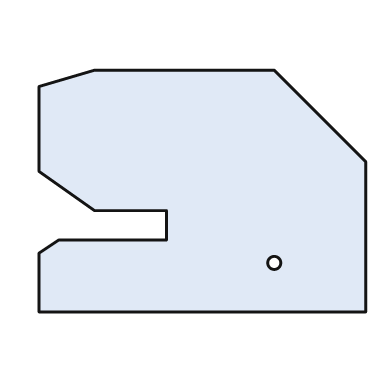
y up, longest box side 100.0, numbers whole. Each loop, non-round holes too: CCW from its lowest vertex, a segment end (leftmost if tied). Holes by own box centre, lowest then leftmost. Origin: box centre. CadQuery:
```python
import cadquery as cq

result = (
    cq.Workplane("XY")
    .moveTo(-50.0, -37.0)
    .lineTo(50.0, -37.0)
    .lineTo(50.0, 9.0)
    .lineTo(22.0, 37.0)
    .lineTo(-33.0, 37.0)
    .lineTo(-50.0, 32.0)
    .lineTo(-50.0, 6.0)
    .lineTo(-33.0, -6.0)
    .lineTo(-11.0, -6.0)
    .lineTo(-11.0, -15.0)
    .lineTo(-44.0, -15.0)
    .lineTo(-50.0, -19.0)
    .close()
    .moveTo(22.0, -22.0)
    .circle(2.0)
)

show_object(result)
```